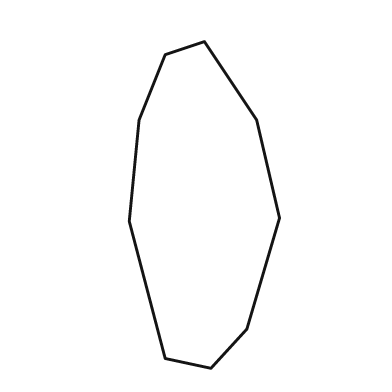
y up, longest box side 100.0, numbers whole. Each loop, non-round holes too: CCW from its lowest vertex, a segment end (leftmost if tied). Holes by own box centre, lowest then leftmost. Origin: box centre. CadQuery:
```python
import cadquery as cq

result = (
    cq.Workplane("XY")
    .moveTo(2.0, -50.0)
    .lineTo(13.0, -38.0)
    .lineTo(23.0, -4.0)
    .lineTo(16.0, 26.0)
    .lineTo(0.0, 50.0)
    .lineTo(-12.0, 46.0)
    .lineTo(-20.0, 26.0)
    .lineTo(-23.0, -5.0)
    .lineTo(-12.0, -47.0)
    .close()
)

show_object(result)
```